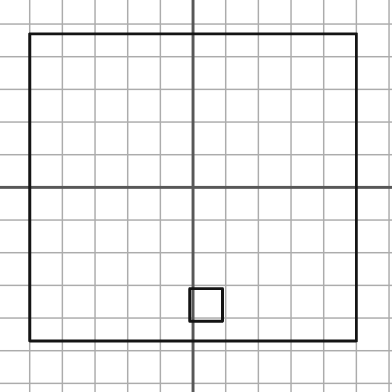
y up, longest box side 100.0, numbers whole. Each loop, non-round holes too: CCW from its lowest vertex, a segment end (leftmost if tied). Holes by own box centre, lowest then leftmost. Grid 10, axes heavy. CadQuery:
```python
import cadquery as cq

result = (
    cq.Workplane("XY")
    .moveTo(-50.0, -47.0)
    .lineTo(50.0, -47.0)
    .lineTo(50.0, 47.0)
    .lineTo(-50.0, 47.0)
    .close()
    .moveTo(-1.0, -41.0)
    .lineTo(9.0, -41.0)
    .lineTo(9.0, -31.0)
    .lineTo(-1.0, -31.0)
    .close()
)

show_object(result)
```